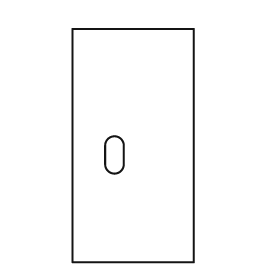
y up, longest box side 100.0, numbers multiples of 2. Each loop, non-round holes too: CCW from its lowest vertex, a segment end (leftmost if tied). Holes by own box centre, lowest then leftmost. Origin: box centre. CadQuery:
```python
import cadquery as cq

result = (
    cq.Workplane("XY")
    .moveTo(-26.0, -50.0)
    .lineTo(26.0, -50.0)
    .lineTo(26.0, 50.0)
    .lineTo(-26.0, 50.0)
    .close()
    .moveTo(-12.0, -8.0)
    .threePointArc((-8.0, -12.0), (-4.0, -8.0))
    .lineTo(-4.0, 0.0)
    .threePointArc((-8.0, 4.0), (-12.0, 0.0))
    .close()
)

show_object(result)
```